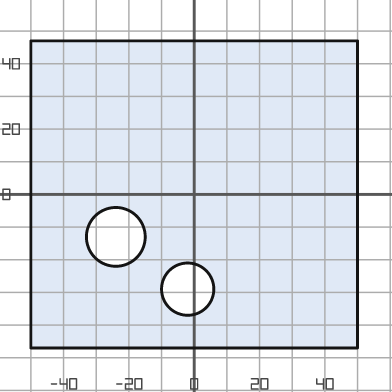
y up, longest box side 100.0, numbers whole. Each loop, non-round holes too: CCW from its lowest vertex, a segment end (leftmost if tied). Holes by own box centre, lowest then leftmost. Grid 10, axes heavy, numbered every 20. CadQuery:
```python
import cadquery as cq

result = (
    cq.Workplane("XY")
    .moveTo(-50.0, -47.0)
    .lineTo(50.0, -47.0)
    .lineTo(50.0, 47.0)
    .lineTo(-50.0, 47.0)
    .close()
    .moveTo(-2.0, -29.0)
    .circle(8.0)
    .moveTo(-24.0, -13.0)
    .circle(9.0)
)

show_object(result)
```